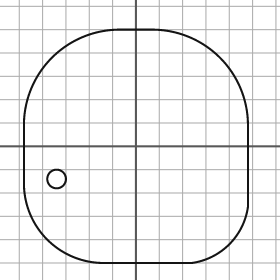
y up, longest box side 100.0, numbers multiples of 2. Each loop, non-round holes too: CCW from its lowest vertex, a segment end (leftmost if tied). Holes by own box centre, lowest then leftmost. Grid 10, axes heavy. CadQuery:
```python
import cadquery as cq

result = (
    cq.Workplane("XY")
    .moveTo(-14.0, -50.0)
    .lineTo(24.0, -50.0)
    .threePointArc((40.0, -42.0), (48.0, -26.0))
    .lineTo(48.0, 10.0)
    .threePointArc((36.0, 38.0), (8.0, 50.0))
    .lineTo(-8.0, 50.0)
    .threePointArc((-36.0, 38.0), (-48.0, 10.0))
    .lineTo(-48.0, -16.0)
    .threePointArc((-38.0, -40.0), (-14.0, -50.0))
    .close()
    .moveTo(-34.0, -14.0)
    .circle(4.0)
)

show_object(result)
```